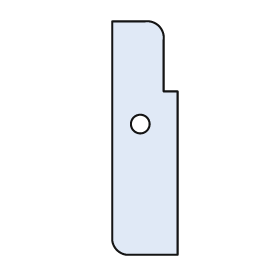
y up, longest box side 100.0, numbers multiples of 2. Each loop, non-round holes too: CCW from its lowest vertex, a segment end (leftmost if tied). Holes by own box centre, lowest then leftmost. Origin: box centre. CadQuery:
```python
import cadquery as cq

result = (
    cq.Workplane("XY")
    .moveTo(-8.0, -50.0)
    .lineTo(14.0, -50.0)
    .lineTo(14.0, 20.0)
    .lineTo(8.0, 20.0)
    .lineTo(8.0, 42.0)
    .threePointArc((6.0, 48.0), (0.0, 50.0))
    .lineTo(-14.0, 50.0)
    .lineTo(-14.0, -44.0)
    .threePointArc((-12.0, -48.0), (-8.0, -50.0))
    .close()
    .moveTo(-2.0, 6.0)
    .circle(4.0)
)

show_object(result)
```